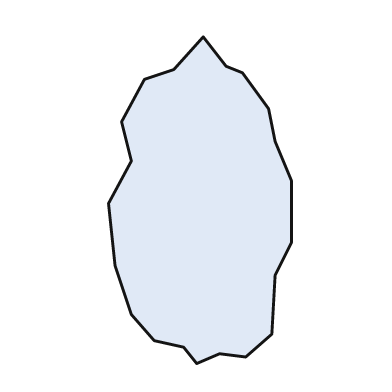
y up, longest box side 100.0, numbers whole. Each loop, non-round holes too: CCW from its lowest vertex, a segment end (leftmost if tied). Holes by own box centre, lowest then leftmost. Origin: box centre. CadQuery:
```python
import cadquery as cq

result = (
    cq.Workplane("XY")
    .moveTo(-1.0, -50.0)
    .lineTo(6.0, -47.0)
    .lineTo(14.0, -48.0)
    .lineTo(22.0, -41.0)
    .lineTo(23.0, -23.0)
    .lineTo(28.0, -13.0)
    .lineTo(28.0, 6.0)
    .lineTo(23.0, 18.0)
    .lineTo(21.0, 28.0)
    .lineTo(13.0, 39.0)
    .lineTo(8.0, 41.0)
    .lineTo(1.0, 50.0)
    .lineTo(-8.0, 40.0)
    .lineTo(-17.0, 37.0)
    .lineTo(-24.0, 24.0)
    .lineTo(-21.0, 12.0)
    .lineTo(-28.0, -1.0)
    .lineTo(-26.0, -20.0)
    .lineTo(-21.0, -35.0)
    .lineTo(-14.0, -43.0)
    .lineTo(-5.0, -45.0)
    .close()
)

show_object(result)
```